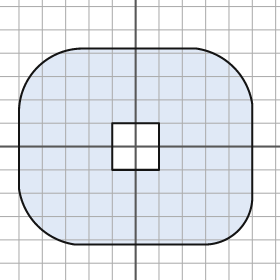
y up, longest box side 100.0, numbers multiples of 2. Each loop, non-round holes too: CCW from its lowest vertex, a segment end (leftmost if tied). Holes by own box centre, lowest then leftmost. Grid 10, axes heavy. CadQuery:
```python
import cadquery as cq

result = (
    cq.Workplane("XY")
    .moveTo(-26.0, -42.0)
    .lineTo(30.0, -42.0)
    .threePointArc((44.0, -36.0), (50.0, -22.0))
    .lineTo(50.0, 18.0)
    .threePointArc((42.0, 34.0), (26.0, 42.0))
    .lineTo(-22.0, 42.0)
    .threePointArc((-42.0, 34.0), (-50.0, 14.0))
    .lineTo(-50.0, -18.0)
    .threePointArc((-42.0, -34.0), (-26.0, -42.0))
    .close()
    .moveTo(-10.0, -10.0)
    .lineTo(10.0, -10.0)
    .lineTo(10.0, 10.0)
    .lineTo(-10.0, 10.0)
    .close()
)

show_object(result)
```